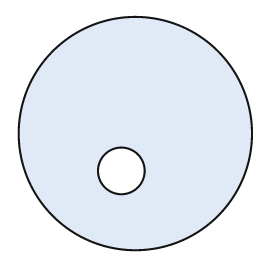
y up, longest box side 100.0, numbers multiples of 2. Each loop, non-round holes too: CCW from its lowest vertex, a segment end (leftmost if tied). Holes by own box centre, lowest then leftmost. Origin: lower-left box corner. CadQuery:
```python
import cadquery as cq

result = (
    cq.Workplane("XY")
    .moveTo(50.0, 50.0)
    .circle(50.0)
    .moveTo(44.0, 34.0)
    .circle(10.0)
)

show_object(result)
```